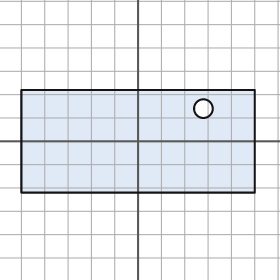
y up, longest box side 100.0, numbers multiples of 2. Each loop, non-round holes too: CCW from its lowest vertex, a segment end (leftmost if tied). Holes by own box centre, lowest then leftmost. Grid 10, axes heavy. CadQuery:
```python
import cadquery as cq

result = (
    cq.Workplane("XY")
    .moveTo(-50.0, -22.0)
    .lineTo(50.0, -22.0)
    .lineTo(50.0, 22.0)
    .lineTo(-50.0, 22.0)
    .close()
    .moveTo(28.0, 14.0)
    .circle(4.0)
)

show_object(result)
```